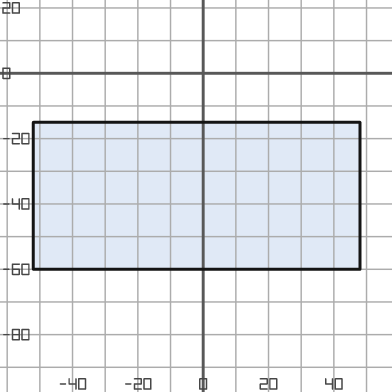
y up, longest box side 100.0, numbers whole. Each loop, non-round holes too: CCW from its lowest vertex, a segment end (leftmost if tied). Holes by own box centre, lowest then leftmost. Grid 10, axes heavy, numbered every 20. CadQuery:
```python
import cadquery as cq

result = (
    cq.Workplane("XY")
    .moveTo(-52.0, -60.0)
    .lineTo(48.0, -60.0)
    .lineTo(48.0, -15.0)
    .lineTo(-52.0, -15.0)
    .close()
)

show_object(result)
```